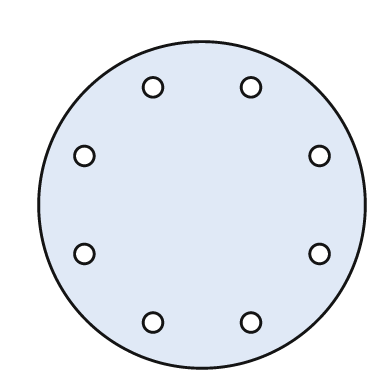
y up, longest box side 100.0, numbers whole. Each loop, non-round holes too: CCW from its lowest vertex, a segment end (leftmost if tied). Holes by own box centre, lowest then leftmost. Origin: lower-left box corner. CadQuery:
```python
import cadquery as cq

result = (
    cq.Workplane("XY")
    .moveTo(50.0, 50.0)
    .circle(50.0)
    .moveTo(35.0, 14.0)
    .circle(3.0)
    .moveTo(65.0, 14.0)
    .circle(3.0)
    .moveTo(14.0, 35.0)
    .circle(3.0)
    .moveTo(86.0, 35.0)
    .circle(3.0)
    .moveTo(14.0, 65.0)
    .circle(3.0)
    .moveTo(86.0, 65.0)
    .circle(3.0)
    .moveTo(35.0, 86.0)
    .circle(3.0)
    .moveTo(65.0, 86.0)
    .circle(3.0)
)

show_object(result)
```